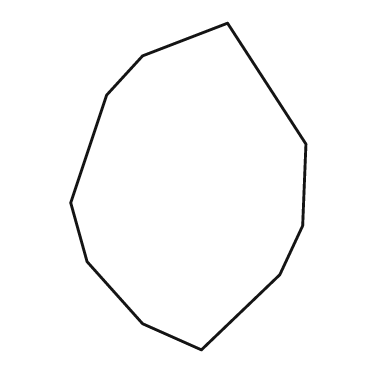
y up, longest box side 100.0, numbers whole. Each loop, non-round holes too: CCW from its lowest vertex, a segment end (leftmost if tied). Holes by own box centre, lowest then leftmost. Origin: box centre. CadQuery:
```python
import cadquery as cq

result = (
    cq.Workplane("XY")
    .moveTo(4.0, -50.0)
    .lineTo(28.0, -27.0)
    .lineTo(35.0, -12.0)
    .lineTo(36.0, 13.0)
    .lineTo(12.0, 50.0)
    .lineTo(-14.0, 40.0)
    .lineTo(-25.0, 28.0)
    .lineTo(-36.0, -5.0)
    .lineTo(-31.0, -23.0)
    .lineTo(-14.0, -42.0)
    .close()
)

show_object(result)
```